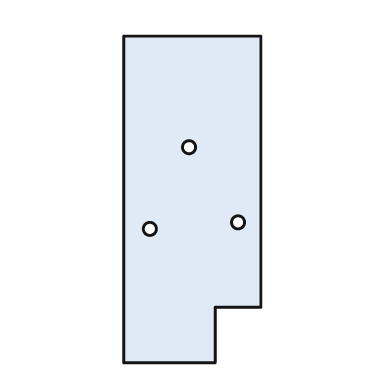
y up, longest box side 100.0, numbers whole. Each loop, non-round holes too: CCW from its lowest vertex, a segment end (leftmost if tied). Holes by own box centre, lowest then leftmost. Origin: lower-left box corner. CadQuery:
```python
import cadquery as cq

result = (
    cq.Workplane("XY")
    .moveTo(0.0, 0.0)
    .lineTo(28.0, 0.0)
    .lineTo(28.0, 17.0)
    .lineTo(42.0, 17.0)
    .lineTo(42.0, 100.0)
    .lineTo(0.0, 100.0)
    .close()
    .moveTo(8.0, 41.0)
    .circle(2.0)
    .moveTo(35.0, 43.0)
    .circle(2.0)
    .moveTo(20.0, 66.0)
    .circle(2.0)
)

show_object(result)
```